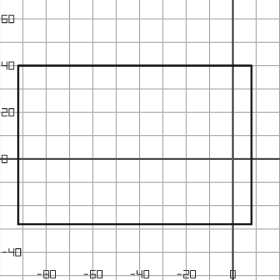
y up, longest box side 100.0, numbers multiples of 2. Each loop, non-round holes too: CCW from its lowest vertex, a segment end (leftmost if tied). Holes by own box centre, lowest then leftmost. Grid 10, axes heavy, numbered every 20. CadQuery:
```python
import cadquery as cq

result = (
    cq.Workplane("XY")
    .moveTo(-92.0, -28.0)
    .lineTo(8.0, -28.0)
    .lineTo(8.0, 40.0)
    .lineTo(-92.0, 40.0)
    .close()
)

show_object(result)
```